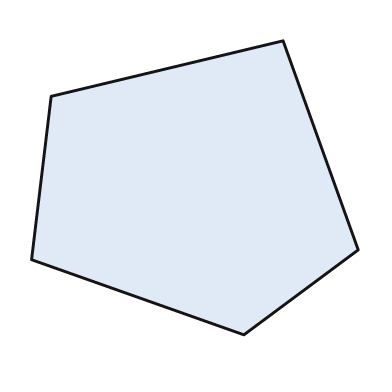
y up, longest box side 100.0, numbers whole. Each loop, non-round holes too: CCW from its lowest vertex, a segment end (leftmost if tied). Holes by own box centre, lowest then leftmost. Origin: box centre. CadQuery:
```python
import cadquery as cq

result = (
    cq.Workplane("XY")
    .moveTo(15.0, -45.0)
    .lineTo(50.0, -19.0)
    .lineTo(27.0, 45.0)
    .lineTo(-44.0, 28.0)
    .lineTo(-50.0, -22.0)
    .close()
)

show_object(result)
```